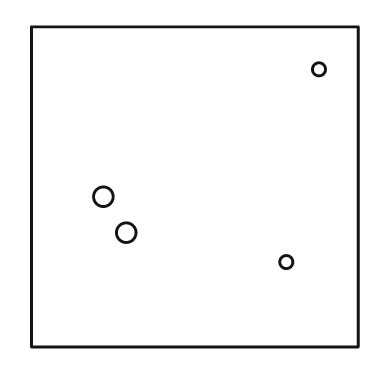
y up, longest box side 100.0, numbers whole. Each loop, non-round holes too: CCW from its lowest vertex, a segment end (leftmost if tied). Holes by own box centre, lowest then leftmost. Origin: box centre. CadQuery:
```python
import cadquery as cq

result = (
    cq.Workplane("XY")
    .moveTo(-50.0, -49.0)
    .lineTo(50.0, -49.0)
    .lineTo(50.0, 49.0)
    .lineTo(-50.0, 49.0)
    .close()
    .moveTo(28.0, -23.0)
    .circle(2.0)
    .moveTo(-21.0, -14.0)
    .circle(3.0)
    .moveTo(-28.0, -3.0)
    .circle(3.0)
    .moveTo(38.0, 36.0)
    .circle(2.0)
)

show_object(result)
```